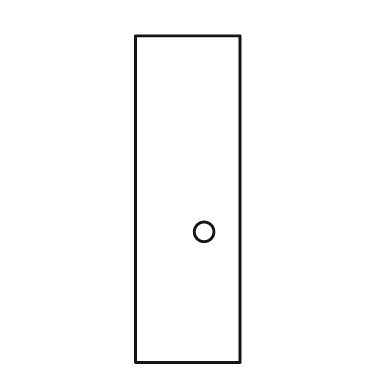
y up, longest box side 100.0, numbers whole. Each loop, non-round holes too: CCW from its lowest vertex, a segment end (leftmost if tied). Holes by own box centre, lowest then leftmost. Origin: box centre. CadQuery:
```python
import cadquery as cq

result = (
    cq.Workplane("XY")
    .moveTo(-16.0, -50.0)
    .lineTo(16.0, -50.0)
    .lineTo(16.0, 50.0)
    .lineTo(-16.0, 50.0)
    .close()
    .moveTo(5.0, -10.0)
    .circle(3.0)
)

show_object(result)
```